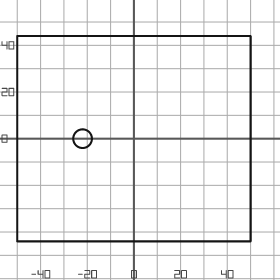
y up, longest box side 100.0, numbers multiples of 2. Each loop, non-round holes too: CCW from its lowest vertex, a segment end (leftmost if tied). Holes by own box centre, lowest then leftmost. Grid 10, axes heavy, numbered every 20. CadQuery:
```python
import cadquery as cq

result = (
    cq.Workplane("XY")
    .moveTo(-50.0, -44.0)
    .lineTo(50.0, -44.0)
    .lineTo(50.0, 44.0)
    .lineTo(-50.0, 44.0)
    .close()
    .moveTo(-22.0, 0.0)
    .circle(4.0)
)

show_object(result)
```